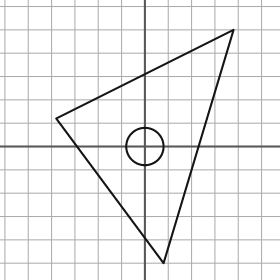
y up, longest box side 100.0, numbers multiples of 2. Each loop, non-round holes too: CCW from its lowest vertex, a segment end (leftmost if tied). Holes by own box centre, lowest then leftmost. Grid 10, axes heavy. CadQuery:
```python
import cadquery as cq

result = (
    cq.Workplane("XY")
    .moveTo(8.0, -50.0)
    .lineTo(38.0, 50.0)
    .lineTo(-38.0, 12.0)
    .close()
    .moveTo(0.0, 0.0)
    .circle(8.0)
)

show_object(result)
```